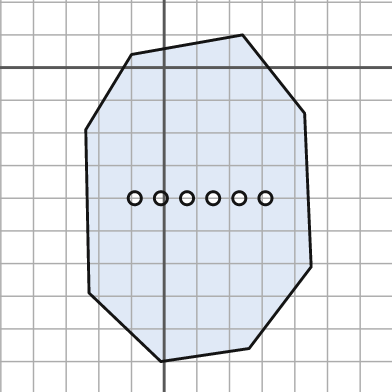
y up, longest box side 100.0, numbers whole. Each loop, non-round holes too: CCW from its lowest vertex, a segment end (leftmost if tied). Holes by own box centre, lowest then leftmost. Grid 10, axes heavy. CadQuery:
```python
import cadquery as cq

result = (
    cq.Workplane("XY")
    .moveTo(-1.0, -90.0)
    .lineTo(26.0, -86.0)
    .lineTo(45.0, -61.0)
    .lineTo(43.0, -14.0)
    .lineTo(24.0, 10.0)
    .lineTo(-10.0, 4.0)
    .lineTo(-24.0, -19.0)
    .lineTo(-23.0, -69.0)
    .close()
    .moveTo(-9.0, -40.0)
    .circle(2.0)
    .moveTo(-1.0, -40.0)
    .circle(2.0)
    .moveTo(7.0, -40.0)
    .circle(2.0)
    .moveTo(15.0, -40.0)
    .circle(2.0)
    .moveTo(23.0, -40.0)
    .circle(2.0)
    .moveTo(31.0, -40.0)
    .circle(2.0)
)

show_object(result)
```